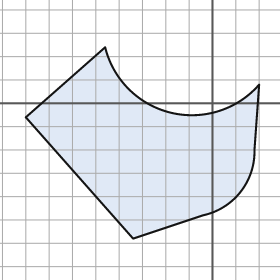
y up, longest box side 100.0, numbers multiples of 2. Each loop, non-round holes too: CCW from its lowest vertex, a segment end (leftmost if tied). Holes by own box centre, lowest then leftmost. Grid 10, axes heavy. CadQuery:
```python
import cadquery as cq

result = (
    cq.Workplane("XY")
    .moveTo(-34.0, -58.0)
    .lineTo(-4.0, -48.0)
    .threePointArc((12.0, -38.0), (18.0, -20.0))
    .lineTo(20.0, 8.0)
    .threePointArc((-18.0, -4.0), (-46.0, 24.0))
    .lineTo(-80.0, -6.0)
    .close()
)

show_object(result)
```